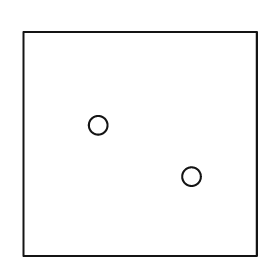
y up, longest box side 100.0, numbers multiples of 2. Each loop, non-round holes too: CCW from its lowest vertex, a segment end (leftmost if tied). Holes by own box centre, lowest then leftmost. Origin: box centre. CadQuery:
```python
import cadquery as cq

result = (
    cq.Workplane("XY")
    .moveTo(-50.0, -48.0)
    .lineTo(50.0, -48.0)
    .lineTo(50.0, 48.0)
    .lineTo(-50.0, 48.0)
    .close()
    .moveTo(22.0, -14.0)
    .circle(4.0)
    .moveTo(-18.0, 8.0)
    .circle(4.0)
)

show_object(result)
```